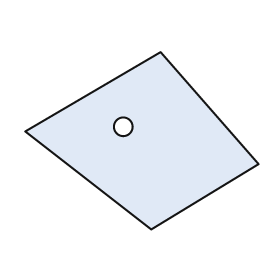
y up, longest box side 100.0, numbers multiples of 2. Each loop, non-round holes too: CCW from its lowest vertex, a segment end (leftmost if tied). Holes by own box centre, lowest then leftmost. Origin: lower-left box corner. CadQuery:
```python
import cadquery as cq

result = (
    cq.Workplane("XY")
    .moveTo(54.0, 0.0)
    .lineTo(100.0, 28.0)
    .lineTo(58.0, 76.0)
    .lineTo(0.0, 42.0)
    .close()
    .moveTo(42.0, 44.0)
    .circle(4.0)
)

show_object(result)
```